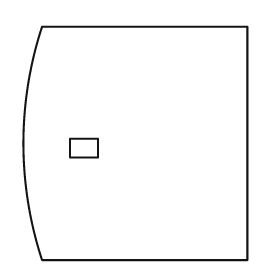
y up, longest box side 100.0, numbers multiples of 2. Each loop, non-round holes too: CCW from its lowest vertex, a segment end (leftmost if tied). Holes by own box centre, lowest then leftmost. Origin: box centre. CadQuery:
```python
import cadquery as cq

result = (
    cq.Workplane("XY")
    .moveTo(-40.0, -50.0)
    .lineTo(48.0, -50.0)
    .lineTo(48.0, 50.0)
    .lineTo(-40.0, 50.0)
    .threePointArc((-48.0, 0.0), (-40.0, -50.0))
    .close()
    .moveTo(-28.0, -6.0)
    .lineTo(-16.0, -6.0)
    .lineTo(-16.0, 2.0)
    .lineTo(-28.0, 2.0)
    .close()
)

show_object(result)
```